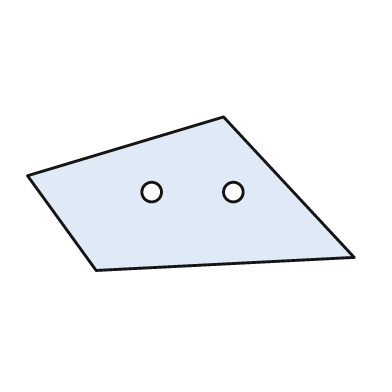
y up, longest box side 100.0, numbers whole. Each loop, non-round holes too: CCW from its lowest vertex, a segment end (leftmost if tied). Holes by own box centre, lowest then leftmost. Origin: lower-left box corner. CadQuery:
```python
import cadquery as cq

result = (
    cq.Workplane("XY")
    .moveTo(21.0, 0.0)
    .lineTo(100.0, 4.0)
    .lineTo(60.0, 47.0)
    .lineTo(0.0, 29.0)
    .close()
    .moveTo(38.0, 24.0)
    .circle(3.0)
    .moveTo(63.0, 24.0)
    .circle(3.0)
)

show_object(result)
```